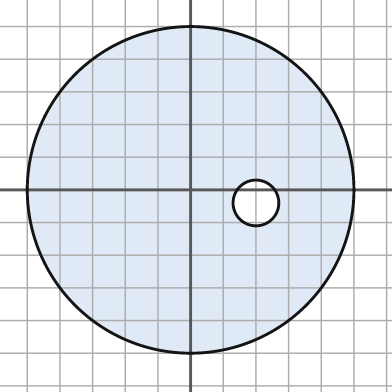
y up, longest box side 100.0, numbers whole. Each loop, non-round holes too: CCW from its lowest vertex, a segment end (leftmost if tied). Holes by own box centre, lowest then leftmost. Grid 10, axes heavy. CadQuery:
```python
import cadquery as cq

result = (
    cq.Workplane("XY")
    .moveTo(0.0, 0.0)
    .circle(50.0)
    .moveTo(20.0, -4.0)
    .circle(7.0)
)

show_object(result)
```